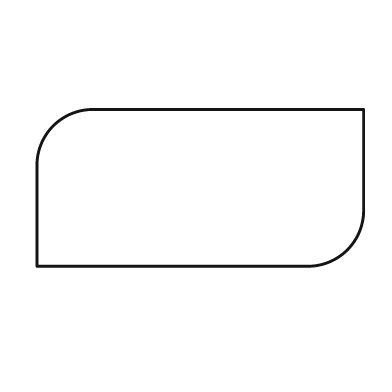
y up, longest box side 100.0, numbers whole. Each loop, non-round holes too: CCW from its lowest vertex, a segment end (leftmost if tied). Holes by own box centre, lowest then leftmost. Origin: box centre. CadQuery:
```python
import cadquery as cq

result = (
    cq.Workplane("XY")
    .moveTo(-50.0, -24.0)
    .lineTo(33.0, -24.0)
    .threePointArc((45.0, -19.0), (50.0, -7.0))
    .lineTo(50.0, 24.0)
    .lineTo(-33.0, 24.0)
    .threePointArc((-45.0, 19.0), (-50.0, 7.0))
    .close()
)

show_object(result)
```